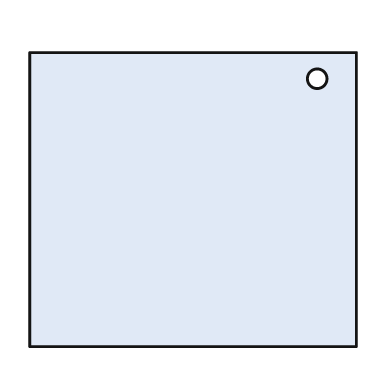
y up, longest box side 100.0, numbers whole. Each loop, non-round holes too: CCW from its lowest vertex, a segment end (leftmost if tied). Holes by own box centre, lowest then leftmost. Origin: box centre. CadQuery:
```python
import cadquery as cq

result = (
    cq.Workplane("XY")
    .moveTo(-50.0, -45.0)
    .lineTo(50.0, -45.0)
    .lineTo(50.0, 45.0)
    .lineTo(-50.0, 45.0)
    .close()
    .moveTo(38.0, 37.0)
    .circle(3.0)
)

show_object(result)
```